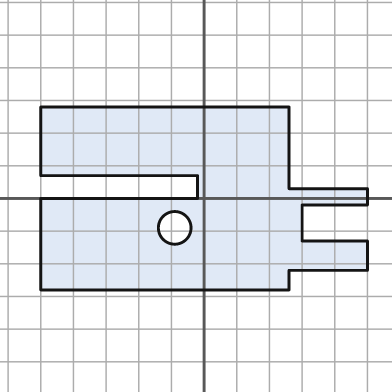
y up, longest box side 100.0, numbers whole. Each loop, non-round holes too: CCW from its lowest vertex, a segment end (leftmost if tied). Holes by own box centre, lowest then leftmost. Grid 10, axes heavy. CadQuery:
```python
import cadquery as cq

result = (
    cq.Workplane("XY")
    .moveTo(-50.0, -28.0)
    .lineTo(26.0, -28.0)
    .lineTo(26.0, -22.0)
    .lineTo(50.0, -22.0)
    .lineTo(50.0, -13.0)
    .lineTo(30.0, -13.0)
    .lineTo(30.0, -2.0)
    .lineTo(50.0, -2.0)
    .lineTo(50.0, 3.0)
    .lineTo(26.0, 3.0)
    .lineTo(26.0, 28.0)
    .lineTo(-50.0, 28.0)
    .lineTo(-50.0, 7.0)
    .lineTo(-2.0, 7.0)
    .lineTo(-2.0, 0.0)
    .lineTo(-50.0, 0.0)
    .close()
    .moveTo(-9.0, -9.0)
    .circle(5.0)
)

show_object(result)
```